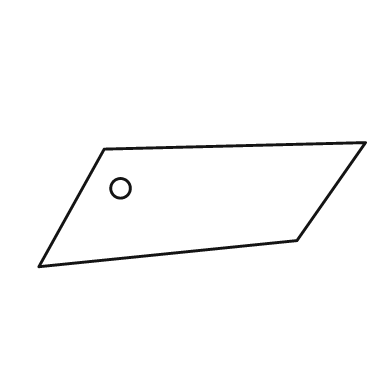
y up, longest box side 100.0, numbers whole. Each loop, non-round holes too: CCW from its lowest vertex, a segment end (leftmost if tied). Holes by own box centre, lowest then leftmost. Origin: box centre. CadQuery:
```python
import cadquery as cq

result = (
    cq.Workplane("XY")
    .moveTo(-50.0, -19.0)
    .lineTo(29.0, -11.0)
    .lineTo(50.0, 19.0)
    .lineTo(-30.0, 17.0)
    .close()
    .moveTo(-25.0, 5.0)
    .circle(3.0)
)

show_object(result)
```